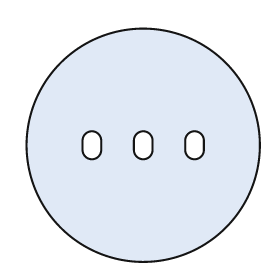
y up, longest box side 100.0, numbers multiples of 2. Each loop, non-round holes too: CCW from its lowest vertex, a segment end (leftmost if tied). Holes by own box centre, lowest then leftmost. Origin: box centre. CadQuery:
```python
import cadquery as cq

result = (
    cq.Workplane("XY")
    .moveTo(0.0, 0.0)
    .circle(50.0)
    .moveTo(-26.0, -2.0)
    .threePointArc((-22.0, -6.0), (-18.0, -2.0))
    .lineTo(-18.0, 2.0)
    .threePointArc((-22.0, 6.0), (-26.0, 2.0))
    .close()
    .moveTo(-4.0, -2.0)
    .threePointArc((0.0, -6.0), (4.0, -2.0))
    .lineTo(4.0, 2.0)
    .threePointArc((0.0, 6.0), (-4.0, 2.0))
    .close()
    .moveTo(18.0, -2.0)
    .threePointArc((22.0, -6.0), (26.0, -2.0))
    .lineTo(26.0, 2.0)
    .threePointArc((22.0, 6.0), (18.0, 2.0))
    .close()
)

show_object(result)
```